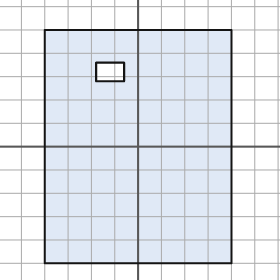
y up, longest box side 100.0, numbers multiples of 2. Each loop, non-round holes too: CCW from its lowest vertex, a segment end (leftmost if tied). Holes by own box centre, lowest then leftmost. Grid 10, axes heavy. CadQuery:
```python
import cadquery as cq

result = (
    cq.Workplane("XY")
    .moveTo(-40.0, -50.0)
    .lineTo(40.0, -50.0)
    .lineTo(40.0, 50.0)
    .lineTo(-40.0, 50.0)
    .close()
    .moveTo(-18.0, 28.0)
    .lineTo(-6.0, 28.0)
    .lineTo(-6.0, 36.0)
    .lineTo(-18.0, 36.0)
    .close()
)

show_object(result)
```